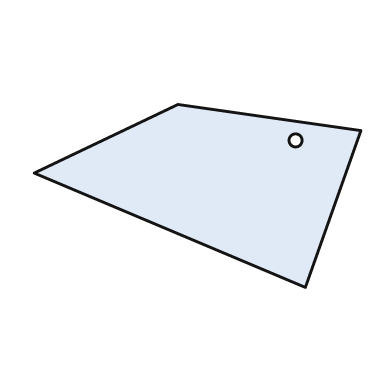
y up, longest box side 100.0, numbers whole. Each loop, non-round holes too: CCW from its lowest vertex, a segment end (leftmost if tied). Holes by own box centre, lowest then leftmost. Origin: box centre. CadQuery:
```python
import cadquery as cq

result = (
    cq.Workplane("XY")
    .moveTo(33.0, -28.0)
    .lineTo(50.0, 20.0)
    .lineTo(-6.0, 28.0)
    .lineTo(-50.0, 7.0)
    .close()
    .moveTo(30.0, 17.0)
    .circle(2.0)
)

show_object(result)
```